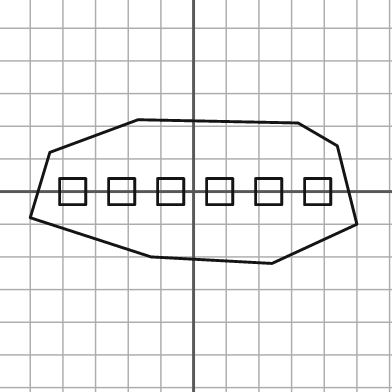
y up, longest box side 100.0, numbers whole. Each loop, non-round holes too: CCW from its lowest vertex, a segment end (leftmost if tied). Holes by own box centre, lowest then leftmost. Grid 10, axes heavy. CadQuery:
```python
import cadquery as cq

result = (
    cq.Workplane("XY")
    .moveTo(24.0, -22.0)
    .lineTo(50.0, -10.0)
    .lineTo(44.0, 14.0)
    .lineTo(32.0, 21.0)
    .lineTo(-17.0, 22.0)
    .lineTo(-44.0, 12.0)
    .lineTo(-50.0, -8.0)
    .lineTo(-13.0, -20.0)
    .close()
    .moveTo(-41.0, -4.0)
    .lineTo(-33.0, -4.0)
    .lineTo(-33.0, 4.0)
    .lineTo(-41.0, 4.0)
    .close()
    .moveTo(-26.0, -4.0)
    .lineTo(-18.0, -4.0)
    .lineTo(-18.0, 4.0)
    .lineTo(-26.0, 4.0)
    .close()
    .moveTo(-11.0, -4.0)
    .lineTo(-3.0, -4.0)
    .lineTo(-3.0, 4.0)
    .lineTo(-11.0, 4.0)
    .close()
    .moveTo(4.0, -4.0)
    .lineTo(12.0, -4.0)
    .lineTo(12.0, 4.0)
    .lineTo(4.0, 4.0)
    .close()
    .moveTo(19.0, -4.0)
    .lineTo(27.0, -4.0)
    .lineTo(27.0, 4.0)
    .lineTo(19.0, 4.0)
    .close()
    .moveTo(34.0, -4.0)
    .lineTo(42.0, -4.0)
    .lineTo(42.0, 4.0)
    .lineTo(34.0, 4.0)
    .close()
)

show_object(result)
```